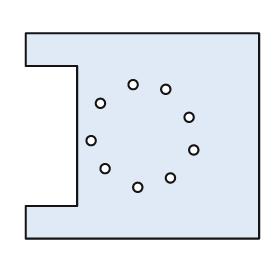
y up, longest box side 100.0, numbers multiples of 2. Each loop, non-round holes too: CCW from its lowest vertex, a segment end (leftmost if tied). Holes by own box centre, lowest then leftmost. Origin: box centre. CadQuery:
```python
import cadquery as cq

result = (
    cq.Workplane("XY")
    .moveTo(-50.0, -44.0)
    .lineTo(50.0, -44.0)
    .lineTo(50.0, 44.0)
    .lineTo(-50.0, 44.0)
    .lineTo(-50.0, 30.0)
    .lineTo(-28.0, 30.0)
    .lineTo(-28.0, -30.0)
    .lineTo(-50.0, -30.0)
    .close()
    .moveTo(-2.0, -22.0)
    .circle(2.0)
    .moveTo(12.0, -18.0)
    .circle(2.0)
    .moveTo(-16.0, -14.0)
    .circle(2.0)
    .moveTo(22.0, -6.0)
    .circle(2.0)
    .moveTo(-22.0, -2.0)
    .circle(2.0)
    .moveTo(20.0, 8.0)
    .circle(2.0)
    .moveTo(-18.0, 14.0)
    .circle(2.0)
    .moveTo(10.0, 20.0)
    .circle(2.0)
    .moveTo(-4.0, 22.0)
    .circle(2.0)
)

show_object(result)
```